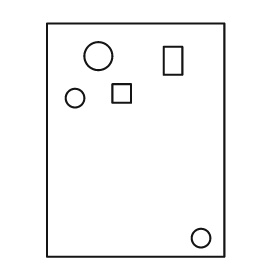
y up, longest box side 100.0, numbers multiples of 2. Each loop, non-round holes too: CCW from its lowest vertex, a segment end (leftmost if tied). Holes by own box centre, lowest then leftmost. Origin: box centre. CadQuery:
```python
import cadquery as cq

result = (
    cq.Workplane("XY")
    .moveTo(-38.0, -50.0)
    .lineTo(38.0, -50.0)
    .lineTo(38.0, 50.0)
    .lineTo(-38.0, 50.0)
    .close()
    .moveTo(28.0, -42.0)
    .circle(4.0)
    .moveTo(-26.0, 18.0)
    .circle(4.0)
    .moveTo(-10.0, 16.0)
    .lineTo(-2.0, 16.0)
    .lineTo(-2.0, 24.0)
    .lineTo(-10.0, 24.0)
    .close()
    .moveTo(12.0, 28.0)
    .lineTo(20.0, 28.0)
    .lineTo(20.0, 40.0)
    .lineTo(12.0, 40.0)
    .close()
    .moveTo(-16.0, 36.0)
    .circle(6.0)
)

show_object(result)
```